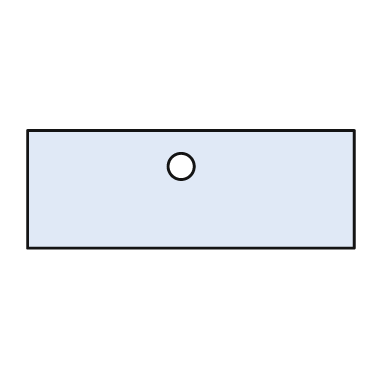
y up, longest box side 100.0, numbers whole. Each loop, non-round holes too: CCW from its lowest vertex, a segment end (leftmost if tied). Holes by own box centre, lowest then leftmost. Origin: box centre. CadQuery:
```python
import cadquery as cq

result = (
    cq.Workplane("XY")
    .moveTo(-50.0, -18.0)
    .lineTo(50.0, -18.0)
    .lineTo(50.0, 18.0)
    .lineTo(-50.0, 18.0)
    .close()
    .moveTo(-3.0, 7.0)
    .circle(4.0)
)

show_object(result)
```